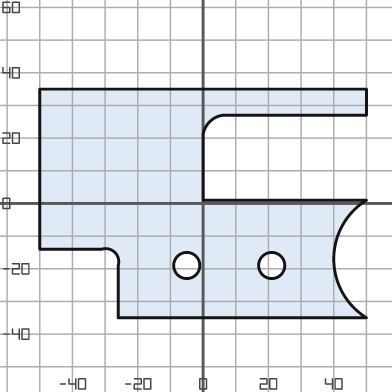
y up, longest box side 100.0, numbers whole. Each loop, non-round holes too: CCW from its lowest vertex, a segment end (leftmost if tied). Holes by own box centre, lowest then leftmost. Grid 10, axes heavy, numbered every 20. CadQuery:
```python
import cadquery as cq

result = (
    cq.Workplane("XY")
    .moveTo(-26.0, -35.0)
    .lineTo(50.0, -35.0)
    .threePointArc((40.0, -17.0), (50.0, 1.0))
    .lineTo(0.0, 1.0)
    .lineTo(0.0, 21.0)
    .threePointArc((2.0, 25.0), (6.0, 27.0))
    .lineTo(50.0, 27.0)
    .lineTo(50.0, 35.0)
    .lineTo(-50.0, 35.0)
    .lineTo(-50.0, -14.0)
    .lineTo(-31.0, -14.0)
    .threePointArc((-27.0, -15.0), (-26.0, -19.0))
    .close()
    .moveTo(-5.0, -19.0)
    .circle(4.0)
    .moveTo(21.0, -19.0)
    .circle(4.0)
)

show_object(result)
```